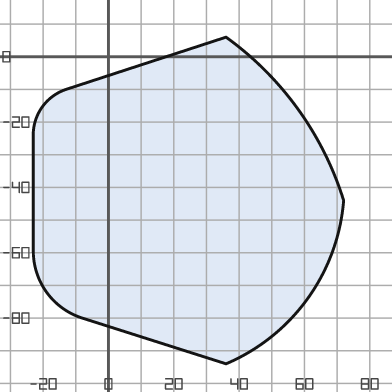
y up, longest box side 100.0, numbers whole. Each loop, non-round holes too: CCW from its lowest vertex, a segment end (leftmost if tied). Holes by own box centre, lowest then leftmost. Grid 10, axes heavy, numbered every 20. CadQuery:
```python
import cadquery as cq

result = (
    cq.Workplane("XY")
    .moveTo(36.0, -94.0)
    .threePointArc((61.0, -74.0), (72.0, -44.0))
    .threePointArc((58.0, -16.0), (36.0, 6.0))
    .lineTo(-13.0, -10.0)
    .threePointArc((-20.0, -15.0), (-23.0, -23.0))
    .lineTo(-23.0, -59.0)
    .threePointArc((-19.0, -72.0), (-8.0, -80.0))
    .close()
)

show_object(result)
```